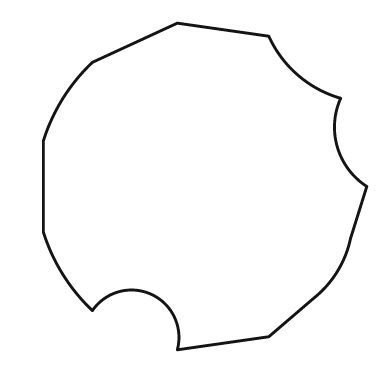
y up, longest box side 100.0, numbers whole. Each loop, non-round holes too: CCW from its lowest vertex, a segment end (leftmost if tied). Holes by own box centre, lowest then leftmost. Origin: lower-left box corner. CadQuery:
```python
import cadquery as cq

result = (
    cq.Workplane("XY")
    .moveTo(41.0, 0.0)
    .lineTo(69.0, 4.0)
    .lineTo(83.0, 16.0)
    .threePointArc((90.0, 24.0), (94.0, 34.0))
    .lineTo(99.0, 50.0)
    .threePointArc((90.0, 62.0), (91.0, 77.0))
    .threePointArc((78.0, 84.0), (69.0, 96.0))
    .lineTo(41.0, 100.0)
    .lineTo(15.0, 88.0)
    .threePointArc((6.0, 77.0), (0.0, 64.0))
    .lineTo(0.0, 36.0)
    .threePointArc((6.0, 23.0), (15.0, 12.0))
    .threePointArc((33.0, 17.0), (41.0, 0.0))
    .close()
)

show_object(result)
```